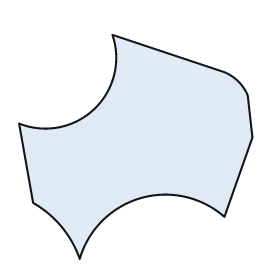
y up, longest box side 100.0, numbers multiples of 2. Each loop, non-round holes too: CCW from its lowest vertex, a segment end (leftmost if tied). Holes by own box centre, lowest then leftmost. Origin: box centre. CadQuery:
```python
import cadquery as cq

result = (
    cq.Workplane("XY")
    .moveTo(-24.0, -48.0)
    .threePointArc((2.0, -22.0), (38.0, -30.0))
    .lineTo(50.0, 4.0)
    .lineTo(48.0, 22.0)
    .threePointArc((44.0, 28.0), (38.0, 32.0))
    .lineTo(-10.0, 48.0)
    .threePointArc((-18.0, 16.0), (-50.0, 10.0))
    .lineTo(-44.0, -24.0)
    .threePointArc((-32.0, -34.0), (-24.0, -48.0))
    .close()
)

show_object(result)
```